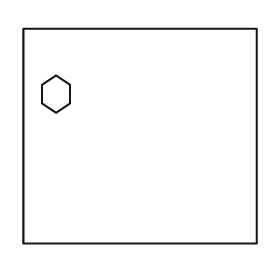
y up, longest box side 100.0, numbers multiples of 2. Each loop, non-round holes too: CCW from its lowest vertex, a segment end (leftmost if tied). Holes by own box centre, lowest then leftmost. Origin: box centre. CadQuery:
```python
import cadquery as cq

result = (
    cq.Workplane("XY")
    .moveTo(-50.0, -46.0)
    .lineTo(50.0, -46.0)
    .lineTo(50.0, 46.0)
    .lineTo(-50.0, 46.0)
    .close()
    .moveTo(-36.0, 10.0)
    .lineTo(-30.0, 14.0)
    .lineTo(-30.0, 22.0)
    .lineTo(-36.0, 26.0)
    .lineTo(-42.0, 22.0)
    .lineTo(-42.0, 14.0)
    .close()
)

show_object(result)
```